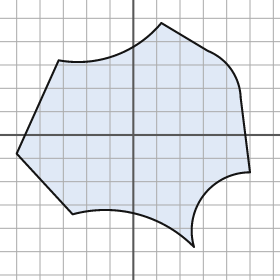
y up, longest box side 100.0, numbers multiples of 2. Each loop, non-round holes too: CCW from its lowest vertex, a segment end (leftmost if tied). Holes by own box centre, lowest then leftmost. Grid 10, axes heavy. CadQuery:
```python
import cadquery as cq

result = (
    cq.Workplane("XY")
    .moveTo(26.0, -48.0)
    .threePointArc((30.0, -26.0), (50.0, -16.0))
    .lineTo(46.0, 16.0)
    .threePointArc((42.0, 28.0), (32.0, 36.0))
    .lineTo(12.0, 48.0)
    .threePointArc((-8.0, 34.0), (-32.0, 32.0))
    .lineTo(-50.0, -8.0)
    .lineTo(-26.0, -34.0)
    .threePointArc((2.0, -34.0), (26.0, -48.0))
    .close()
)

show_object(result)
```